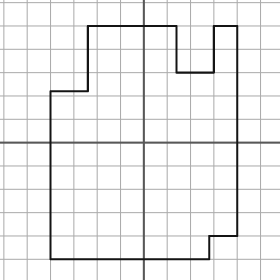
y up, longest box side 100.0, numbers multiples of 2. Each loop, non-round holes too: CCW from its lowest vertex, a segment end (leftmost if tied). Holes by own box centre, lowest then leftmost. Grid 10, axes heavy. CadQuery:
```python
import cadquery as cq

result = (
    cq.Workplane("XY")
    .moveTo(-40.0, -50.0)
    .lineTo(28.0, -50.0)
    .lineTo(28.0, -40.0)
    .lineTo(40.0, -40.0)
    .lineTo(40.0, 50.0)
    .lineTo(30.0, 50.0)
    .lineTo(30.0, 30.0)
    .lineTo(14.0, 30.0)
    .lineTo(14.0, 50.0)
    .lineTo(-24.0, 50.0)
    .lineTo(-24.0, 22.0)
    .lineTo(-40.0, 22.0)
    .close()
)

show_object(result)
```